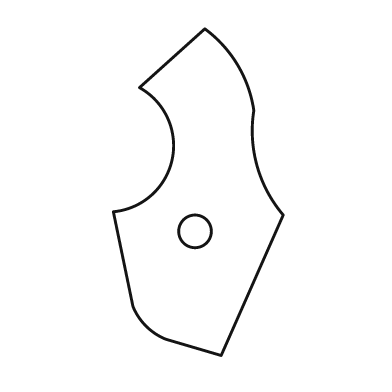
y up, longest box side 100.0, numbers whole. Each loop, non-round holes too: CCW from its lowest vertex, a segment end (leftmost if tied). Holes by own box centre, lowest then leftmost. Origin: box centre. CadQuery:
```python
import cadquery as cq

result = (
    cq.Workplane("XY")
    .moveTo(7.0, -50.0)
    .lineTo(26.0, -7.0)
    .threePointArc((18.0, 8.0), (17.0, 25.0))
    .threePointArc((12.0, 39.0), (2.0, 50.0))
    .lineTo(-18.0, 32.0)
    .threePointArc((-8.0, 10.0), (-26.0, -6.0))
    .lineTo(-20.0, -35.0)
    .threePointArc((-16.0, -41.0), (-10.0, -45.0))
    .close()
    .moveTo(-1.0, -12.0)
    .circle(5.0)
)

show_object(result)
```